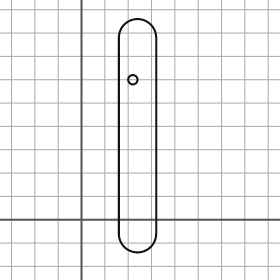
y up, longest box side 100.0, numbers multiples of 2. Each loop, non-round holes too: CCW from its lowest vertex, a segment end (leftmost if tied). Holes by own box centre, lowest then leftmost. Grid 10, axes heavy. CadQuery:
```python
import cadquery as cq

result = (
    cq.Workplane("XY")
    .moveTo(16.0, -6.0)
    .threePointArc((24.0, -14.0), (32.0, -6.0))
    .lineTo(32.0, 78.0)
    .threePointArc((24.0, 86.0), (16.0, 78.0))
    .close()
    .moveTo(22.0, 60.0)
    .circle(2.0)
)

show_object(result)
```